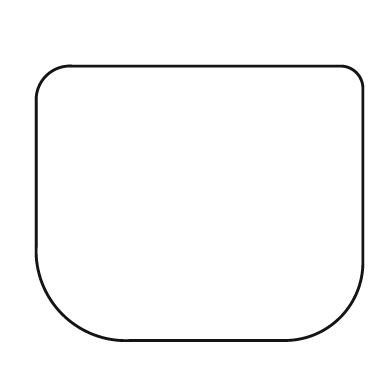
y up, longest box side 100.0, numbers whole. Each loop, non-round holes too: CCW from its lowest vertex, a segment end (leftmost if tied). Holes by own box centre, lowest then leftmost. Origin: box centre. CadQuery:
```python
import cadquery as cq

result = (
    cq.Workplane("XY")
    .moveTo(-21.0, -42.0)
    .lineTo(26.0, -42.0)
    .threePointArc((43.0, -35.0), (50.0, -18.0))
    .lineTo(50.0, 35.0)
    .threePointArc((48.0, 40.0), (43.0, 42.0))
    .lineTo(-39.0, 42.0)
    .threePointArc((-47.0, 39.0), (-50.0, 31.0))
    .lineTo(-50.0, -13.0)
    .threePointArc((-42.0, -34.0), (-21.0, -42.0))
    .close()
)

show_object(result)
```